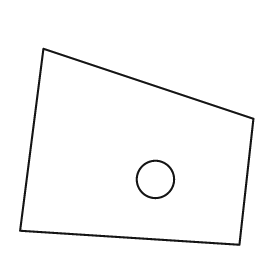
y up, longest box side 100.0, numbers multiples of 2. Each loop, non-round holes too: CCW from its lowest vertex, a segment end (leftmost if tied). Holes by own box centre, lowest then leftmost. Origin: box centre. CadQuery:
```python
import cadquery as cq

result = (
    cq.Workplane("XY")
    .moveTo(44.0, -42.0)
    .lineTo(50.0, 12.0)
    .lineTo(-40.0, 42.0)
    .lineTo(-50.0, -36.0)
    .close()
    .moveTo(8.0, -14.0)
    .circle(8.0)
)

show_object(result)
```